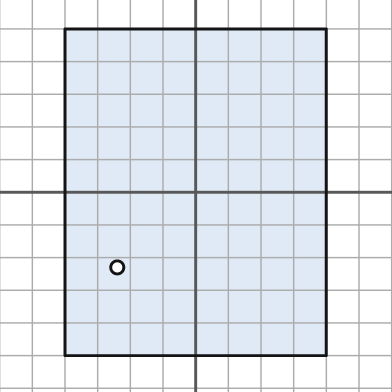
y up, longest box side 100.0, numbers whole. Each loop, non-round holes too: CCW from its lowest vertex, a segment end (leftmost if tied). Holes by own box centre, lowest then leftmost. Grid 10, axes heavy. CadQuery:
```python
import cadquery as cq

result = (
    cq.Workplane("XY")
    .moveTo(-40.0, -50.0)
    .lineTo(40.0, -50.0)
    .lineTo(40.0, 50.0)
    .lineTo(-40.0, 50.0)
    .close()
    .moveTo(-24.0, -23.0)
    .circle(2.0)
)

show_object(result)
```